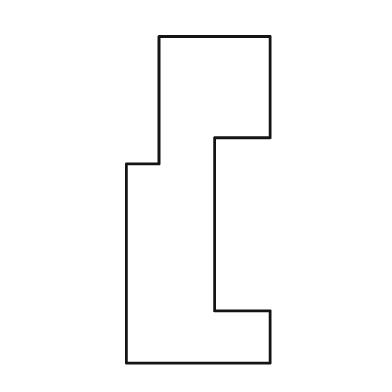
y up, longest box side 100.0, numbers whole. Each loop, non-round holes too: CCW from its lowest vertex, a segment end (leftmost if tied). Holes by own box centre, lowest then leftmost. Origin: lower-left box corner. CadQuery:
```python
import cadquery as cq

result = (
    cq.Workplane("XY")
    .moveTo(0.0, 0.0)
    .lineTo(44.0, 0.0)
    .lineTo(44.0, 16.0)
    .lineTo(27.0, 16.0)
    .lineTo(27.0, 69.0)
    .lineTo(44.0, 69.0)
    .lineTo(44.0, 100.0)
    .lineTo(10.0, 100.0)
    .lineTo(10.0, 61.0)
    .lineTo(0.0, 61.0)
    .close()
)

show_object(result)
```